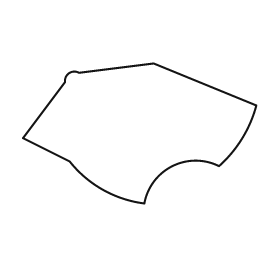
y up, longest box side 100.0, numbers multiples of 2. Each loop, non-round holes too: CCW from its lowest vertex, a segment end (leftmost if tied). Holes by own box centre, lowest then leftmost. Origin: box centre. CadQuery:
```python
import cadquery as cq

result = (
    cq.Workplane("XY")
    .moveTo(2.0, -30.0)
    .threePointArc((14.0, -14.0), (34.0, -14.0))
    .threePointArc((44.0, -2.0), (50.0, 12.0))
    .lineTo(6.0, 30.0)
    .lineTo(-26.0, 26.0)
    .threePointArc((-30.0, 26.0), (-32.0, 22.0))
    .lineTo(-50.0, -2.0)
    .lineTo(-30.0, -12.0)
    .threePointArc((-16.0, -24.0), (2.0, -30.0))
    .close()
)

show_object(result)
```